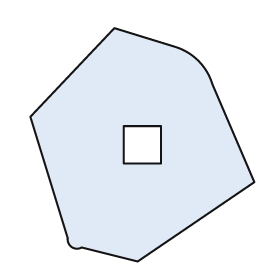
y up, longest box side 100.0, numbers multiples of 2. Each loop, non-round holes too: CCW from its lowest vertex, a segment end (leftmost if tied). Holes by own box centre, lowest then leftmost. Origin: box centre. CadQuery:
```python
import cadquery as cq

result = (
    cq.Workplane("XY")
    .moveTo(-2.0, -50.0)
    .lineTo(48.0, -16.0)
    .lineTo(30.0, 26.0)
    .threePointArc((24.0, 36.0), (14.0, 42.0))
    .lineTo(-12.0, 50.0)
    .lineTo(-48.0, 12.0)
    .lineTo(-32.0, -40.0)
    .threePointArc((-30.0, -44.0), (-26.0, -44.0))
    .close()
    .moveTo(-8.0, -8.0)
    .lineTo(8.0, -8.0)
    .lineTo(8.0, 8.0)
    .lineTo(-8.0, 8.0)
    .close()
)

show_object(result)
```